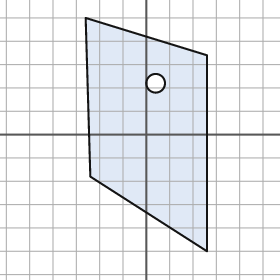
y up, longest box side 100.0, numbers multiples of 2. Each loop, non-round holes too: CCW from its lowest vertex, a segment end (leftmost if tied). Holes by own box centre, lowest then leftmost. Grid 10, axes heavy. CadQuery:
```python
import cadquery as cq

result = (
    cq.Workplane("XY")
    .moveTo(26.0, -50.0)
    .lineTo(26.0, 34.0)
    .lineTo(-26.0, 50.0)
    .lineTo(-24.0, -18.0)
    .close()
    .moveTo(4.0, 22.0)
    .circle(4.0)
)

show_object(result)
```